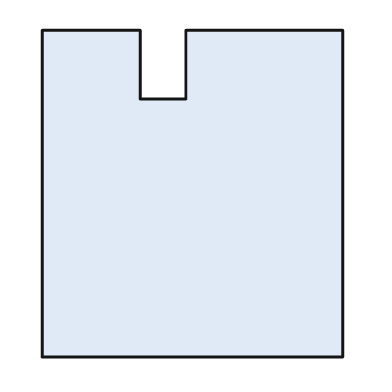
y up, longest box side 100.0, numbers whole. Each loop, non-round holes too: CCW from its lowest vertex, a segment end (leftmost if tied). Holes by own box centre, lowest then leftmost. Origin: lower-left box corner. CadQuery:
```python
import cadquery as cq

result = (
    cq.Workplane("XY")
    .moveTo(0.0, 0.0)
    .lineTo(92.0, 0.0)
    .lineTo(92.0, 100.0)
    .lineTo(44.0, 100.0)
    .lineTo(44.0, 79.0)
    .lineTo(30.0, 79.0)
    .lineTo(30.0, 100.0)
    .lineTo(0.0, 100.0)
    .close()
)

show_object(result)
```